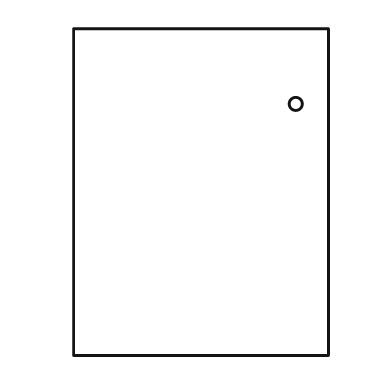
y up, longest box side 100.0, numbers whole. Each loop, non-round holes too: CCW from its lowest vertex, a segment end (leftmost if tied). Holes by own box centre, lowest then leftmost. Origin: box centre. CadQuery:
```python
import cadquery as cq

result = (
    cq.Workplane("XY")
    .moveTo(-39.0, -50.0)
    .lineTo(39.0, -50.0)
    .lineTo(39.0, 50.0)
    .lineTo(-39.0, 50.0)
    .close()
    .moveTo(29.0, 27.0)
    .circle(2.0)
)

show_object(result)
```